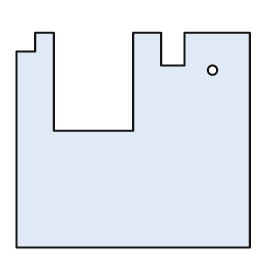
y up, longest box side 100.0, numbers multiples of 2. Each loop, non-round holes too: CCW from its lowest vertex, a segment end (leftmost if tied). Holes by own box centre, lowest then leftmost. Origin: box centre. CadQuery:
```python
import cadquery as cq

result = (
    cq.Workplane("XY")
    .moveTo(-50.0, -46.0)
    .lineTo(50.0, -46.0)
    .lineTo(50.0, 46.0)
    .lineTo(22.0, 46.0)
    .lineTo(22.0, 32.0)
    .lineTo(12.0, 32.0)
    .lineTo(12.0, 46.0)
    .lineTo(0.0, 46.0)
    .lineTo(0.0, 4.0)
    .lineTo(-34.0, 4.0)
    .lineTo(-34.0, 46.0)
    .lineTo(-42.0, 46.0)
    .lineTo(-42.0, 38.0)
    .lineTo(-50.0, 38.0)
    .close()
    .moveTo(34.0, 30.0)
    .circle(2.0)
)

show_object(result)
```